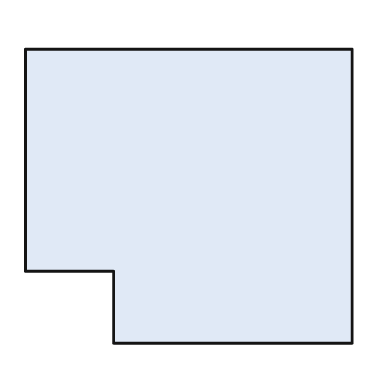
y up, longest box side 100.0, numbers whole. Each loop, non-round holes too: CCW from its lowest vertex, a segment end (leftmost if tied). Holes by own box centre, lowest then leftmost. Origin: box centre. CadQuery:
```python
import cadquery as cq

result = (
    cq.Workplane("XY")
    .moveTo(-23.0, -45.0)
    .lineTo(50.0, -45.0)
    .lineTo(50.0, 45.0)
    .lineTo(-50.0, 45.0)
    .lineTo(-50.0, -23.0)
    .lineTo(-23.0, -23.0)
    .close()
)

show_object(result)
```